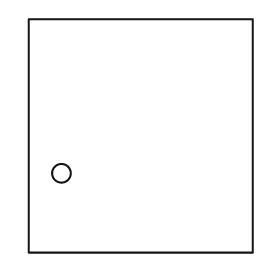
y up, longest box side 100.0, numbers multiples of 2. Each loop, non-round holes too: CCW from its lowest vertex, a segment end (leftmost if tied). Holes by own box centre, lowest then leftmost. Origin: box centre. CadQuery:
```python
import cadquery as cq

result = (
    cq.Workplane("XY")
    .moveTo(-48.0, -50.0)
    .lineTo(48.0, -50.0)
    .lineTo(48.0, 50.0)
    .lineTo(-48.0, 50.0)
    .close()
    .moveTo(-34.0, -16.0)
    .circle(4.0)
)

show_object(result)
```